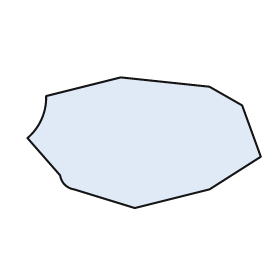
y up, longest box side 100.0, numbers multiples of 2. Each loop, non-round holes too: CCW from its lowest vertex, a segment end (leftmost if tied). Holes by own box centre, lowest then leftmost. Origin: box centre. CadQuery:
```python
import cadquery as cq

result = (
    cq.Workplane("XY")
    .moveTo(-4.0, -28.0)
    .lineTo(28.0, -20.0)
    .lineTo(50.0, -6.0)
    .lineTo(42.0, 16.0)
    .lineTo(28.0, 24.0)
    .lineTo(-10.0, 28.0)
    .lineTo(-42.0, 20.0)
    .threePointArc((-44.0, 10.0), (-50.0, 2.0))
    .lineTo(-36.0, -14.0)
    .threePointArc((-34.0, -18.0), (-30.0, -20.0))
    .close()
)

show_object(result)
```